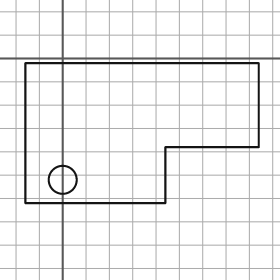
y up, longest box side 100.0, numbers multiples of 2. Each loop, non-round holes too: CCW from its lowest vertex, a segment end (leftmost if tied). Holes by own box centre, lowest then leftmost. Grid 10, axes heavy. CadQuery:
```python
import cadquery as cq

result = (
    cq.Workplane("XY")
    .moveTo(-16.0, -62.0)
    .lineTo(44.0, -62.0)
    .lineTo(44.0, -38.0)
    .lineTo(84.0, -38.0)
    .lineTo(84.0, -2.0)
    .lineTo(-16.0, -2.0)
    .close()
    .moveTo(0.0, -52.0)
    .circle(6.0)
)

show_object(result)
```